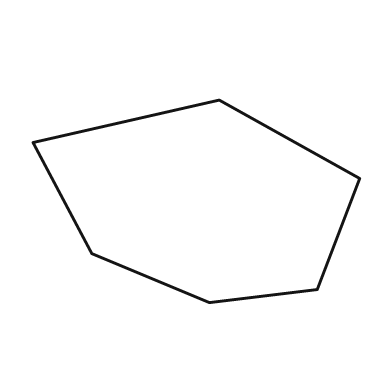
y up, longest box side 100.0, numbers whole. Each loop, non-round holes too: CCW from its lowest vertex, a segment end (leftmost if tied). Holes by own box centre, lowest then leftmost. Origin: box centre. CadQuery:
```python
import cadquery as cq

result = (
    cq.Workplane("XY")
    .moveTo(4.0, -31.0)
    .lineTo(37.0, -27.0)
    .lineTo(50.0, 7.0)
    .lineTo(7.0, 31.0)
    .lineTo(-50.0, 18.0)
    .lineTo(-32.0, -16.0)
    .close()
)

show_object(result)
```